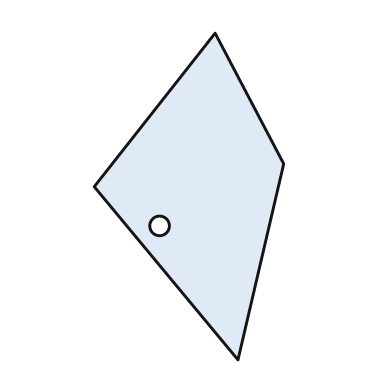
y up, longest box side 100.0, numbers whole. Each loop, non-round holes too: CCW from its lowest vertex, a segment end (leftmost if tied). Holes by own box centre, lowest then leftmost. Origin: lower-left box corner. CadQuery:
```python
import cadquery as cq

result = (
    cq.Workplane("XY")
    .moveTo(44.0, 0.0)
    .lineTo(58.0, 60.0)
    .lineTo(37.0, 100.0)
    .lineTo(0.0, 53.0)
    .close()
    .moveTo(20.0, 41.0)
    .circle(3.0)
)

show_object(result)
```